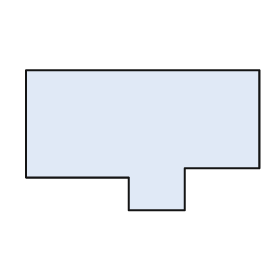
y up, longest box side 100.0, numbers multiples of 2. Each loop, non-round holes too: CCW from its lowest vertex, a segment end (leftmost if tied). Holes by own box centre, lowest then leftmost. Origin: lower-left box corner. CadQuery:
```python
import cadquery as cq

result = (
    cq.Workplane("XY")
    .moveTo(44.0, 0.0)
    .lineTo(68.0, 0.0)
    .lineTo(68.0, 18.0)
    .lineTo(100.0, 18.0)
    .lineTo(100.0, 60.0)
    .lineTo(0.0, 60.0)
    .lineTo(0.0, 14.0)
    .lineTo(44.0, 14.0)
    .close()
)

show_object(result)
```